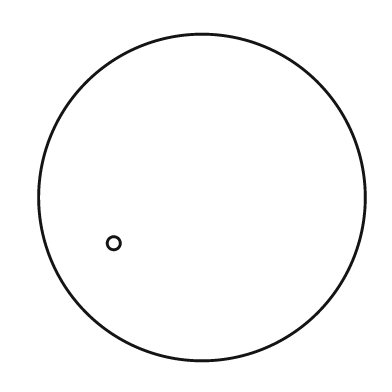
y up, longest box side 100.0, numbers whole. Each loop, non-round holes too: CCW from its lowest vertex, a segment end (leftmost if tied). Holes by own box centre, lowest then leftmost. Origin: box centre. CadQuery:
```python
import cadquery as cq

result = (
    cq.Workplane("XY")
    .moveTo(0.0, 0.0)
    .circle(50.0)
    .moveTo(-27.0, -14.0)
    .circle(2.0)
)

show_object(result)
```